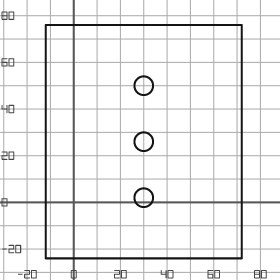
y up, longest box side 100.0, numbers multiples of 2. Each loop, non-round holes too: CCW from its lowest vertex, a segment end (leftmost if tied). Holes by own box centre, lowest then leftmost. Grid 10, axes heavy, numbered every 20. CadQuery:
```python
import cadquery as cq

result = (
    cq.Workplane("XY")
    .moveTo(-12.0, -24.0)
    .lineTo(72.0, -24.0)
    .lineTo(72.0, 76.0)
    .lineTo(-12.0, 76.0)
    .close()
    .moveTo(30.0, 2.0)
    .circle(4.0)
    .moveTo(30.0, 26.0)
    .circle(4.0)
    .moveTo(30.0, 50.0)
    .circle(4.0)
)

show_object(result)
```